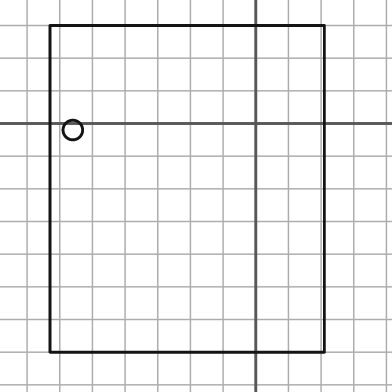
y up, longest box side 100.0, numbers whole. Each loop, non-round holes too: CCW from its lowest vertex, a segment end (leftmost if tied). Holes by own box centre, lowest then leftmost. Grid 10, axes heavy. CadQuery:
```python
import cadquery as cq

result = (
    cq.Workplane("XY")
    .moveTo(-63.0, -70.0)
    .lineTo(21.0, -70.0)
    .lineTo(21.0, 30.0)
    .lineTo(-63.0, 30.0)
    .close()
    .moveTo(-56.0, -2.0)
    .circle(3.0)
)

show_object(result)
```